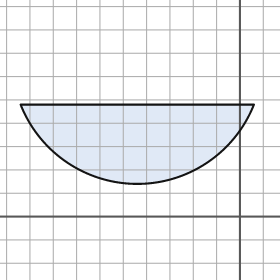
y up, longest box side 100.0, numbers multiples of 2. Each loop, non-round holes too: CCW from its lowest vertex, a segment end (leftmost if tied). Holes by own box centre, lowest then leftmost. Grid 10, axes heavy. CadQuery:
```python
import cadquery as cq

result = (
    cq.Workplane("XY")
    .moveTo(-94.0, 48.0)
    .threePointArc((-44.0, 14.0), (6.0, 48.0))
    .close()
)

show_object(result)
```